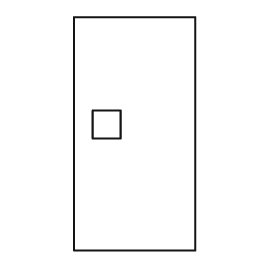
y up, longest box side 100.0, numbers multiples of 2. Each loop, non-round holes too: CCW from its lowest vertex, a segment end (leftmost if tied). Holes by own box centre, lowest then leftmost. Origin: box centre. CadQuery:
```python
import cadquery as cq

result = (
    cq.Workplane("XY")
    .moveTo(-26.0, -50.0)
    .lineTo(26.0, -50.0)
    .lineTo(26.0, 50.0)
    .lineTo(-26.0, 50.0)
    .close()
    .moveTo(-18.0, -2.0)
    .lineTo(-6.0, -2.0)
    .lineTo(-6.0, 10.0)
    .lineTo(-18.0, 10.0)
    .close()
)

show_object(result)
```